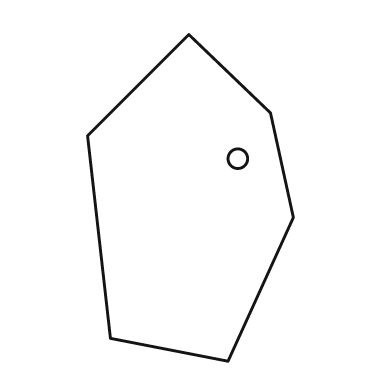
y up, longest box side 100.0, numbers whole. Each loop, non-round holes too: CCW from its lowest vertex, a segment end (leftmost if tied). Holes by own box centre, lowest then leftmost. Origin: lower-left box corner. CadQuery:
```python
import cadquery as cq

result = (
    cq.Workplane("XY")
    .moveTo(43.0, 0.0)
    .lineTo(63.0, 44.0)
    .lineTo(56.0, 76.0)
    .lineTo(31.0, 100.0)
    .lineTo(0.0, 69.0)
    .lineTo(7.0, 7.0)
    .close()
    .moveTo(46.0, 62.0)
    .circle(3.0)
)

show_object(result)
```